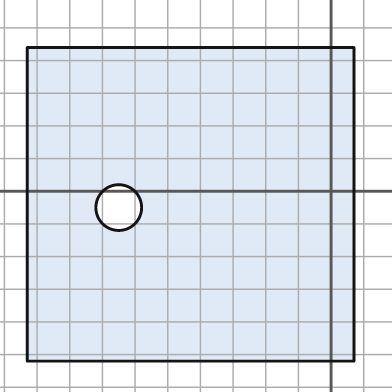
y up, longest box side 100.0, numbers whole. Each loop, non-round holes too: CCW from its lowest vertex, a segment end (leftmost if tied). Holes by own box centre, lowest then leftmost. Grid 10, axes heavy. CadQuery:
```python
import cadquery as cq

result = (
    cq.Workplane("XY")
    .moveTo(-93.0, -52.0)
    .lineTo(7.0, -52.0)
    .lineTo(7.0, 44.0)
    .lineTo(-93.0, 44.0)
    .close()
    .moveTo(-65.0, -5.0)
    .circle(7.0)
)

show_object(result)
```